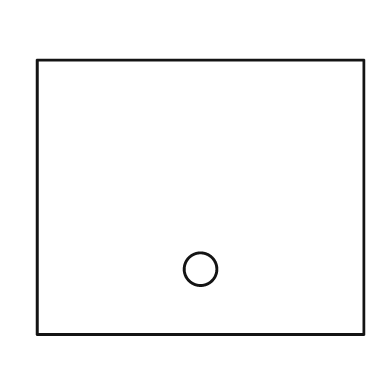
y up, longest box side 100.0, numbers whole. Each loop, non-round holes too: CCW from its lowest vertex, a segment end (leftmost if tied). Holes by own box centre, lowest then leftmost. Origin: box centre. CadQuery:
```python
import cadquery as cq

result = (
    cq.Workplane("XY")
    .moveTo(-50.0, -42.0)
    .lineTo(50.0, -42.0)
    .lineTo(50.0, 42.0)
    .lineTo(-50.0, 42.0)
    .close()
    .moveTo(0.0, -22.0)
    .circle(5.0)
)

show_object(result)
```